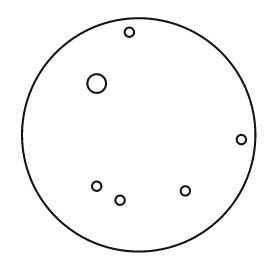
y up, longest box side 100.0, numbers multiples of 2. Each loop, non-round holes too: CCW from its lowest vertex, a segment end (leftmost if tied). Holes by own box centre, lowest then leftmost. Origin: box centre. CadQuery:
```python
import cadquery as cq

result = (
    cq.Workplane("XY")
    .moveTo(0.0, 0.0)
    .circle(50.0)
    .moveTo(-8.0, -28.0)
    .circle(2.0)
    .moveTo(20.0, -24.0)
    .circle(2.0)
    .moveTo(-18.0, -22.0)
    .circle(2.0)
    .moveTo(44.0, -2.0)
    .circle(2.0)
    .moveTo(-18.0, 22.0)
    .circle(4.0)
    .moveTo(-4.0, 44.0)
    .circle(2.0)
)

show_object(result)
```